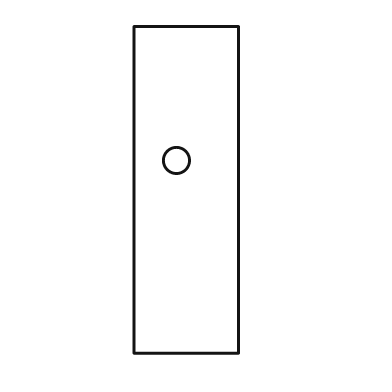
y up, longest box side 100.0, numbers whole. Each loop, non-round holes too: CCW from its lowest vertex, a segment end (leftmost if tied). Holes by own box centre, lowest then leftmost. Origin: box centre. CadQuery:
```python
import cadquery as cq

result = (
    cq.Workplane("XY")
    .moveTo(-16.0, -50.0)
    .lineTo(16.0, -50.0)
    .lineTo(16.0, 50.0)
    .lineTo(-16.0, 50.0)
    .close()
    .moveTo(-3.0, 9.0)
    .circle(4.0)
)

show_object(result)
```